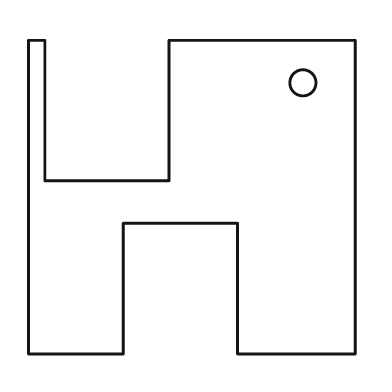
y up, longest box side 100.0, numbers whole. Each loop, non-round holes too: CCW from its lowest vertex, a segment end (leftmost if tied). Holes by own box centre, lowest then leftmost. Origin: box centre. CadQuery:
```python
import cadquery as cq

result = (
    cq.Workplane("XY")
    .moveTo(-50.0, -48.0)
    .lineTo(-21.0, -48.0)
    .lineTo(-21.0, -8.0)
    .lineTo(14.0, -8.0)
    .lineTo(14.0, -48.0)
    .lineTo(50.0, -48.0)
    .lineTo(50.0, 48.0)
    .lineTo(-7.0, 48.0)
    .lineTo(-7.0, 5.0)
    .lineTo(-45.0, 5.0)
    .lineTo(-45.0, 48.0)
    .lineTo(-50.0, 48.0)
    .close()
    .moveTo(34.0, 35.0)
    .circle(4.0)
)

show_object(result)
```